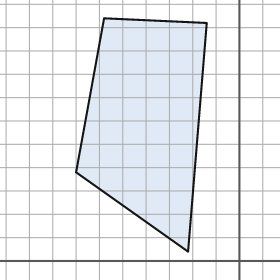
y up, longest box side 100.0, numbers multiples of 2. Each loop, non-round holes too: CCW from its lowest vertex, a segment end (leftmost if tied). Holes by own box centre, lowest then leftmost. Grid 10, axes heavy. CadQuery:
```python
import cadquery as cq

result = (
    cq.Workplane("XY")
    .moveTo(-22.0, 4.0)
    .lineTo(-14.0, 102.0)
    .lineTo(-58.0, 104.0)
    .lineTo(-70.0, 38.0)
    .close()
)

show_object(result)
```